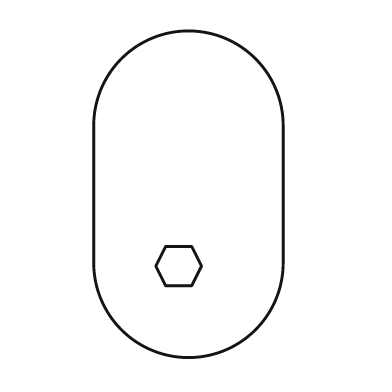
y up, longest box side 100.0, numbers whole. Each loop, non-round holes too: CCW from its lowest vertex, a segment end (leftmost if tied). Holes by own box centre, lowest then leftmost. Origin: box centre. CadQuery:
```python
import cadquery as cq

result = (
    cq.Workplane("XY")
    .moveTo(-29.0, -21.0)
    .threePointArc((0.0, -50.0), (29.0, -21.0))
    .lineTo(29.0, 21.0)
    .threePointArc((0.0, 50.0), (-29.0, 21.0))
    .close()
    .moveTo(-7.0, -28.0)
    .lineTo(1.0, -28.0)
    .lineTo(4.0, -22.0)
    .lineTo(1.0, -16.0)
    .lineTo(-7.0, -16.0)
    .lineTo(-10.0, -22.0)
    .close()
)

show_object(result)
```